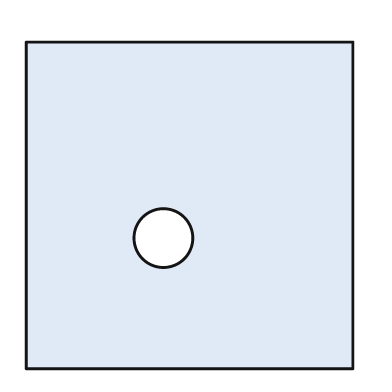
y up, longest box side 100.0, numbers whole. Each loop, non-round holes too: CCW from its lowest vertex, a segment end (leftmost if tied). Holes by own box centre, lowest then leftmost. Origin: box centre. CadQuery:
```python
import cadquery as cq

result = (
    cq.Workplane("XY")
    .moveTo(-50.0, -50.0)
    .lineTo(50.0, -50.0)
    .lineTo(50.0, 50.0)
    .lineTo(-50.0, 50.0)
    .close()
    .moveTo(-8.0, -10.0)
    .circle(9.0)
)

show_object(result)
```